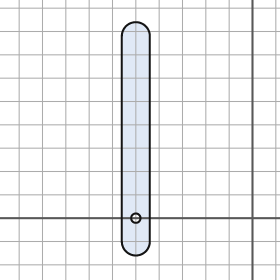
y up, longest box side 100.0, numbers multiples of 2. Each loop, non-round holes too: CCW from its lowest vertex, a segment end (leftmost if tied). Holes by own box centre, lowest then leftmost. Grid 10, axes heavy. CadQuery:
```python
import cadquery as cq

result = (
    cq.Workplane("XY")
    .moveTo(-56.0, -10.0)
    .threePointArc((-50.0, -16.0), (-44.0, -10.0))
    .lineTo(-44.0, 78.0)
    .threePointArc((-50.0, 84.0), (-56.0, 78.0))
    .close()
    .moveTo(-50.0, 0.0)
    .circle(2.0)
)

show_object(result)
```